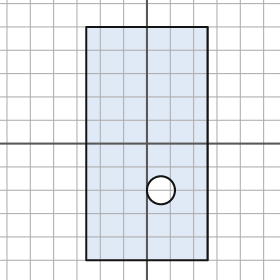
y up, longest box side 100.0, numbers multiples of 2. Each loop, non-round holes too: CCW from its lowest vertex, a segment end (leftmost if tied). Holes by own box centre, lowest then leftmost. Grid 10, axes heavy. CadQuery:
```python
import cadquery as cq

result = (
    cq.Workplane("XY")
    .moveTo(-26.0, -50.0)
    .lineTo(26.0, -50.0)
    .lineTo(26.0, 50.0)
    .lineTo(-26.0, 50.0)
    .close()
    .moveTo(6.0, -20.0)
    .circle(6.0)
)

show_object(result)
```